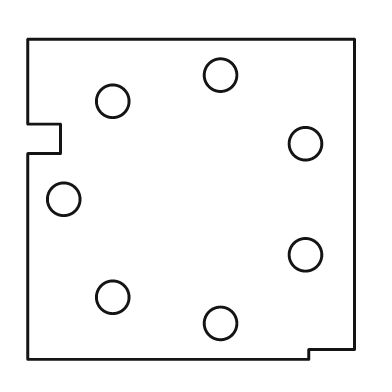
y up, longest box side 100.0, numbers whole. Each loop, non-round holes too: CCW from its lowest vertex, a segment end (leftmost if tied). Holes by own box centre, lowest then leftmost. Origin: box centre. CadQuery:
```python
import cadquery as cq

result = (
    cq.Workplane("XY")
    .moveTo(-50.0, -49.0)
    .lineTo(36.0, -49.0)
    .lineTo(36.0, -46.0)
    .lineTo(50.0, -46.0)
    .lineTo(50.0, 49.0)
    .lineTo(-50.0, 49.0)
    .lineTo(-50.0, 23.0)
    .lineTo(-40.0, 23.0)
    .lineTo(-40.0, 14.0)
    .lineTo(-50.0, 14.0)
    .close()
    .moveTo(9.0, -38.0)
    .circle(5.0)
    .moveTo(-24.0, -30.0)
    .circle(5.0)
    .moveTo(35.0, -17.0)
    .circle(5.0)
    .moveTo(-39.0, 0.0)
    .circle(5.0)
    .moveTo(35.0, 17.0)
    .circle(5.0)
    .moveTo(-24.0, 30.0)
    .circle(5.0)
    .moveTo(9.0, 38.0)
    .circle(5.0)
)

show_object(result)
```